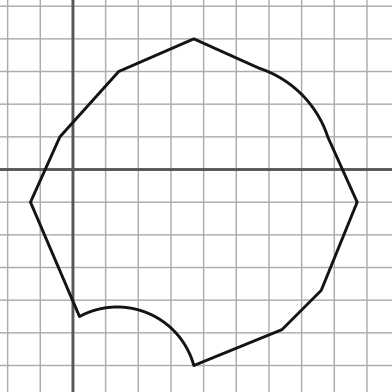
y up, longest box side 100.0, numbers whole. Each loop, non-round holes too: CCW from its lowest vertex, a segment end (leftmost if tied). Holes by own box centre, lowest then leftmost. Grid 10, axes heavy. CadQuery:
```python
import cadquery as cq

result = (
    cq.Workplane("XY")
    .moveTo(37.0, -60.0)
    .lineTo(64.0, -49.0)
    .lineTo(76.0, -37.0)
    .lineTo(87.0, -10.0)
    .lineTo(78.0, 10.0)
    .threePointArc((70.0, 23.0), (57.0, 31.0))
    .lineTo(37.0, 40.0)
    .lineTo(14.0, 30.0)
    .lineTo(-4.0, 10.0)
    .lineTo(-13.0, -10.0)
    .lineTo(2.0, -45.0)
    .threePointArc((23.0, -44.0), (37.0, -60.0))
    .close()
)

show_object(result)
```